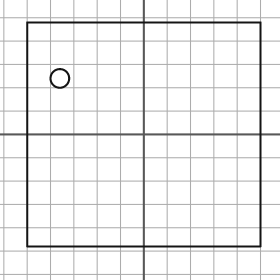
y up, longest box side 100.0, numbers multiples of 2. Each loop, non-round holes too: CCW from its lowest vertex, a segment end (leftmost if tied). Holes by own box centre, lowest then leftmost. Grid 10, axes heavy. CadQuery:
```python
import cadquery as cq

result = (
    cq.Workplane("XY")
    .moveTo(-50.0, -48.0)
    .lineTo(50.0, -48.0)
    .lineTo(50.0, 48.0)
    .lineTo(-50.0, 48.0)
    .close()
    .moveTo(-36.0, 24.0)
    .circle(4.0)
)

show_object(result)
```